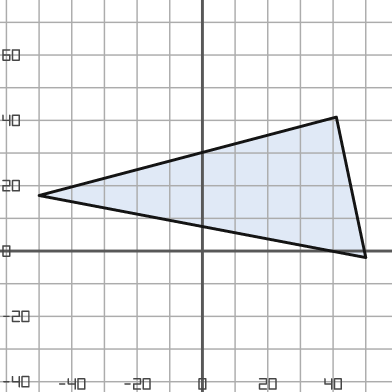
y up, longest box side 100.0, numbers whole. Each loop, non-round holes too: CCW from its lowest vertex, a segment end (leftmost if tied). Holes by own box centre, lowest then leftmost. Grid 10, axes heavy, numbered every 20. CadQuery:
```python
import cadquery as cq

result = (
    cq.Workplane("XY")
    .moveTo(50.0, -2.0)
    .lineTo(41.0, 41.0)
    .lineTo(-50.0, 17.0)
    .close()
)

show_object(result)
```